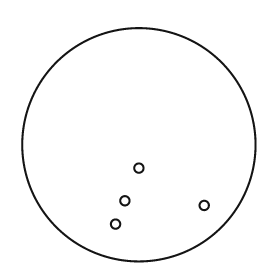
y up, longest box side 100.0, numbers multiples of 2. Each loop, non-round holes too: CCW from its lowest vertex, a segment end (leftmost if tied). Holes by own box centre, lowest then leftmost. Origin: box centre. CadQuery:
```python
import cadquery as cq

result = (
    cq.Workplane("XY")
    .moveTo(0.0, 0.0)
    .circle(50.0)
    .moveTo(-10.0, -34.0)
    .circle(2.0)
    .moveTo(28.0, -26.0)
    .circle(2.0)
    .moveTo(-6.0, -24.0)
    .circle(2.0)
    .moveTo(0.0, -10.0)
    .circle(2.0)
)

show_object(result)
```